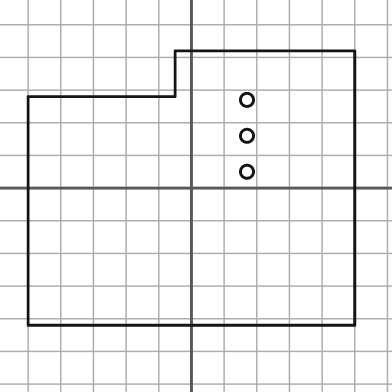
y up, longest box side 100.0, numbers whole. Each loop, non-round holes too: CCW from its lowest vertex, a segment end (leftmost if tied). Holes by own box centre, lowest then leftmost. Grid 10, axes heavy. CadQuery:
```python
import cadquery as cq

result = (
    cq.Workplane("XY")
    .moveTo(-50.0, -42.0)
    .lineTo(50.0, -42.0)
    .lineTo(50.0, 42.0)
    .lineTo(-5.0, 42.0)
    .lineTo(-5.0, 28.0)
    .lineTo(-50.0, 28.0)
    .close()
    .moveTo(17.0, 5.0)
    .circle(2.0)
    .moveTo(17.0, 16.0)
    .circle(2.0)
    .moveTo(17.0, 27.0)
    .circle(2.0)
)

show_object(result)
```